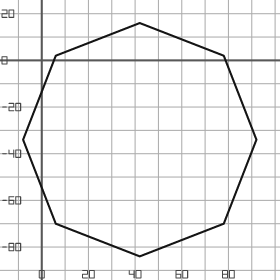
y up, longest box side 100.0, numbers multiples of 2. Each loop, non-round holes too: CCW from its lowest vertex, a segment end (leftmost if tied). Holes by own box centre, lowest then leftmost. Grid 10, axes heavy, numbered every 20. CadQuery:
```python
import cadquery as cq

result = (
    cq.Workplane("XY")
    .moveTo(42.0, -84.0)
    .lineTo(78.0, -70.0)
    .lineTo(92.0, -34.0)
    .lineTo(78.0, 2.0)
    .lineTo(42.0, 16.0)
    .lineTo(6.0, 2.0)
    .lineTo(-8.0, -34.0)
    .lineTo(6.0, -70.0)
    .close()
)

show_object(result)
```